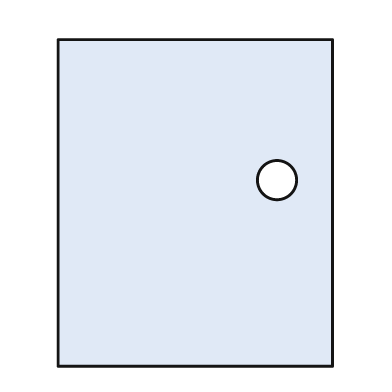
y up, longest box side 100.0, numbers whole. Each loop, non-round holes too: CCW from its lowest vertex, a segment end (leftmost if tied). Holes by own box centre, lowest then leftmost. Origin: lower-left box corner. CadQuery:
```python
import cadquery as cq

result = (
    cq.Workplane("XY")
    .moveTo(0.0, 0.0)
    .lineTo(84.0, 0.0)
    .lineTo(84.0, 100.0)
    .lineTo(0.0, 100.0)
    .close()
    .moveTo(67.0, 57.0)
    .circle(6.0)
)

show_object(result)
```